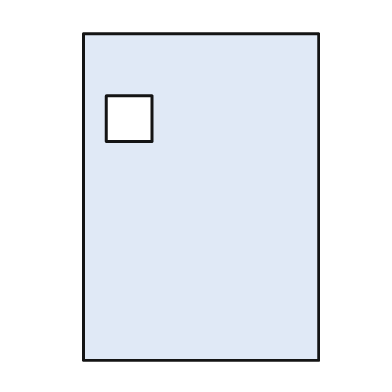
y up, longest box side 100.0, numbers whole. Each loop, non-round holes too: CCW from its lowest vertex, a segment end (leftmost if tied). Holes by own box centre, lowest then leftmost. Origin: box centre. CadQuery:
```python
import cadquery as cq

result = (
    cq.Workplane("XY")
    .moveTo(-36.0, -50.0)
    .lineTo(36.0, -50.0)
    .lineTo(36.0, 50.0)
    .lineTo(-36.0, 50.0)
    .close()
    .moveTo(-29.0, 17.0)
    .lineTo(-15.0, 17.0)
    .lineTo(-15.0, 31.0)
    .lineTo(-29.0, 31.0)
    .close()
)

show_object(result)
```